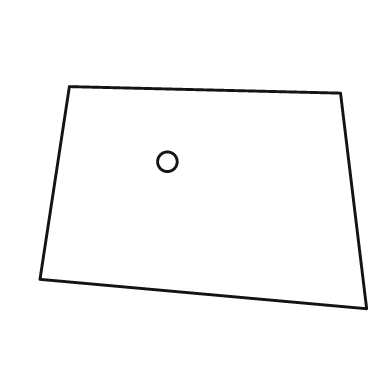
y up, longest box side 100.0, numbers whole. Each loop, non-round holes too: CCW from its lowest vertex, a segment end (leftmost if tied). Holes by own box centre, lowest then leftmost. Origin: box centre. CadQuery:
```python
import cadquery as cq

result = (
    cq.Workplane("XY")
    .moveTo(50.0, -34.0)
    .lineTo(42.0, 32.0)
    .lineTo(-41.0, 34.0)
    .lineTo(-50.0, -25.0)
    .close()
    .moveTo(-11.0, 11.0)
    .circle(3.0)
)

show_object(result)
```